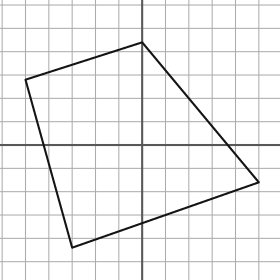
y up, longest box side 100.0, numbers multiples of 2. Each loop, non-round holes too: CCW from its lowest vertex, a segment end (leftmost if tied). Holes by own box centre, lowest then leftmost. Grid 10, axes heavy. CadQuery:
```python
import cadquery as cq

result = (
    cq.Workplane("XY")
    .moveTo(-30.0, -44.0)
    .lineTo(50.0, -16.0)
    .lineTo(0.0, 44.0)
    .lineTo(-50.0, 28.0)
    .close()
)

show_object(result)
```